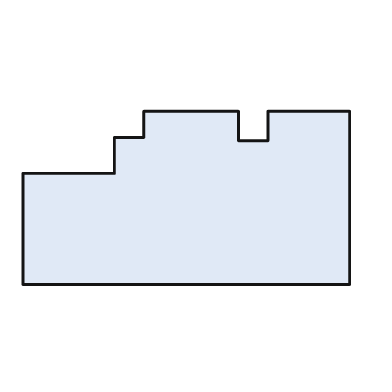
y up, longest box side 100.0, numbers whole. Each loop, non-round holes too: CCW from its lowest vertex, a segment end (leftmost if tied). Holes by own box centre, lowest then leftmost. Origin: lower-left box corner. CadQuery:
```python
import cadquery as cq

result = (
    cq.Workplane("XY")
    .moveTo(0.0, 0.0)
    .lineTo(100.0, 0.0)
    .lineTo(100.0, 53.0)
    .lineTo(75.0, 53.0)
    .lineTo(75.0, 44.0)
    .lineTo(66.0, 44.0)
    .lineTo(66.0, 53.0)
    .lineTo(37.0, 53.0)
    .lineTo(37.0, 45.0)
    .lineTo(28.0, 45.0)
    .lineTo(28.0, 34.0)
    .lineTo(0.0, 34.0)
    .close()
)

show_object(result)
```